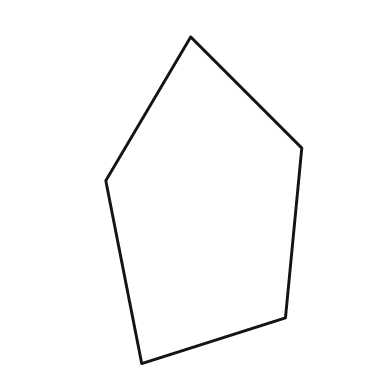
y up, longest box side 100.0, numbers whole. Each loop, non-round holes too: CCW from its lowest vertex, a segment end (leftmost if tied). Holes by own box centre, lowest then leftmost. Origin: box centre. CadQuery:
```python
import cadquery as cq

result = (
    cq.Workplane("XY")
    .moveTo(-19.0, -50.0)
    .lineTo(25.0, -36.0)
    .lineTo(30.0, 16.0)
    .lineTo(-4.0, 50.0)
    .lineTo(-30.0, 6.0)
    .close()
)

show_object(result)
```